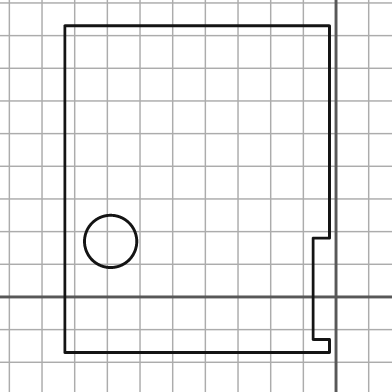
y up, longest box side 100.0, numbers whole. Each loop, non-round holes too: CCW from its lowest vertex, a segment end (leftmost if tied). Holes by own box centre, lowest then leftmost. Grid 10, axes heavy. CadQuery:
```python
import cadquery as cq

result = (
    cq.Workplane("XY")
    .moveTo(-83.0, -17.0)
    .lineTo(-2.0, -17.0)
    .lineTo(-2.0, -13.0)
    .lineTo(-7.0, -13.0)
    .lineTo(-7.0, 18.0)
    .lineTo(-2.0, 18.0)
    .lineTo(-2.0, 83.0)
    .lineTo(-83.0, 83.0)
    .close()
    .moveTo(-69.0, 17.0)
    .circle(8.0)
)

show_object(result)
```